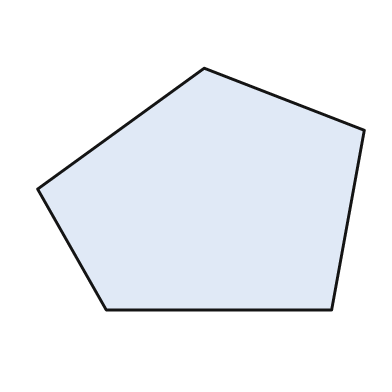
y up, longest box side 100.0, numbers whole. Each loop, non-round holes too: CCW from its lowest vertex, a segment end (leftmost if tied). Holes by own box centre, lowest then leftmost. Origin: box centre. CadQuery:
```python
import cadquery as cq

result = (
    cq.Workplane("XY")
    .moveTo(-29.0, -37.0)
    .lineTo(40.0, -37.0)
    .lineTo(50.0, 18.0)
    .lineTo(1.0, 37.0)
    .lineTo(-50.0, 0.0)
    .close()
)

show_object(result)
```